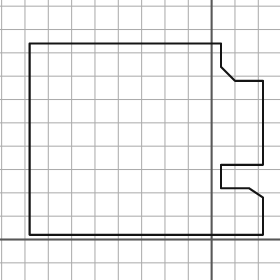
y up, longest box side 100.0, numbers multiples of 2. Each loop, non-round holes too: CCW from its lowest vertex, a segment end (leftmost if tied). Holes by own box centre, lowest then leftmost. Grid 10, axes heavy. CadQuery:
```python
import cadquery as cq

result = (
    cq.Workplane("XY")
    .moveTo(-78.0, 2.0)
    .lineTo(22.0, 2.0)
    .lineTo(22.0, 18.0)
    .lineTo(16.0, 22.0)
    .lineTo(4.0, 22.0)
    .lineTo(4.0, 32.0)
    .lineTo(22.0, 32.0)
    .lineTo(22.0, 68.0)
    .lineTo(10.0, 68.0)
    .lineTo(4.0, 74.0)
    .lineTo(4.0, 84.0)
    .lineTo(-78.0, 84.0)
    .close()
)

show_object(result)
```